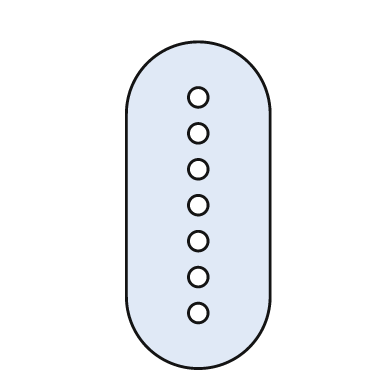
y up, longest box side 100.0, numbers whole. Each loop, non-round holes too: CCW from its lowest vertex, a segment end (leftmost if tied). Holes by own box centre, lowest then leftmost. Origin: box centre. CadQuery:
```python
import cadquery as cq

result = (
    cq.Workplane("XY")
    .moveTo(-22.0, -28.0)
    .threePointArc((0.0, -50.0), (22.0, -28.0))
    .lineTo(22.0, 28.0)
    .threePointArc((0.0, 50.0), (-22.0, 28.0))
    .close()
    .moveTo(0.0, -33.0)
    .circle(3.0)
    .moveTo(0.0, -22.0)
    .circle(3.0)
    .moveTo(0.0, -11.0)
    .circle(3.0)
    .moveTo(0.0, 0.0)
    .circle(3.0)
    .moveTo(0.0, 11.0)
    .circle(3.0)
    .moveTo(0.0, 22.0)
    .circle(3.0)
    .moveTo(0.0, 33.0)
    .circle(3.0)
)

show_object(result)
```